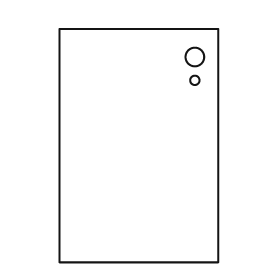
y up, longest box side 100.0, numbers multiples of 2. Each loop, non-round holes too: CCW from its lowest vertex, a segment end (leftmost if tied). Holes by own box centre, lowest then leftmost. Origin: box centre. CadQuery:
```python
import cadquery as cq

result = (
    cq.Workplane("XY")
    .moveTo(-34.0, -50.0)
    .lineTo(34.0, -50.0)
    .lineTo(34.0, 50.0)
    .lineTo(-34.0, 50.0)
    .close()
    .moveTo(24.0, 28.0)
    .circle(2.0)
    .moveTo(24.0, 38.0)
    .circle(4.0)
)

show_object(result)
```